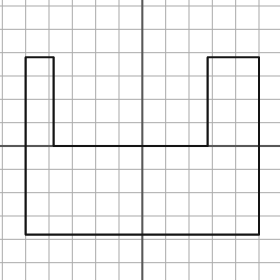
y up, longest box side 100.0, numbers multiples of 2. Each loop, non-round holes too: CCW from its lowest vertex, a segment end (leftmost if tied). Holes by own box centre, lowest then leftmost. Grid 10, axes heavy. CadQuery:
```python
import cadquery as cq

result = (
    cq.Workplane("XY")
    .moveTo(-50.0, -38.0)
    .lineTo(50.0, -38.0)
    .lineTo(50.0, 38.0)
    .lineTo(28.0, 38.0)
    .lineTo(28.0, 0.0)
    .lineTo(-38.0, 0.0)
    .lineTo(-38.0, 38.0)
    .lineTo(-50.0, 38.0)
    .close()
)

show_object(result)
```